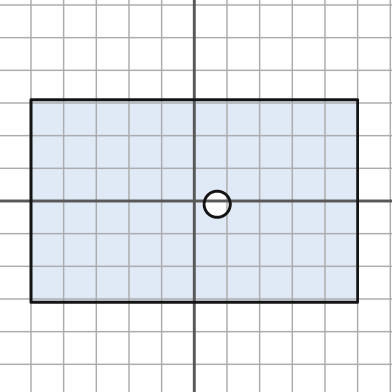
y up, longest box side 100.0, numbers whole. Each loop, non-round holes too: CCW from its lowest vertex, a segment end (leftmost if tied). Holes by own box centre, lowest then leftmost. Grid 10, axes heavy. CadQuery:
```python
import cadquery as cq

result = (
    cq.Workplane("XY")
    .moveTo(-50.0, -31.0)
    .lineTo(50.0, -31.0)
    .lineTo(50.0, 31.0)
    .lineTo(-50.0, 31.0)
    .close()
    .moveTo(7.0, -1.0)
    .circle(4.0)
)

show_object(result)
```